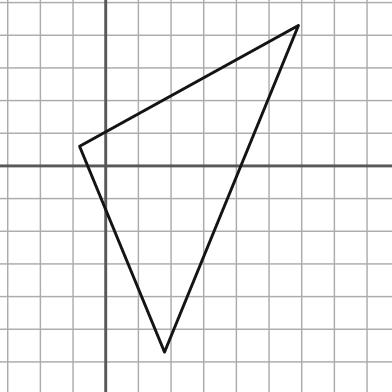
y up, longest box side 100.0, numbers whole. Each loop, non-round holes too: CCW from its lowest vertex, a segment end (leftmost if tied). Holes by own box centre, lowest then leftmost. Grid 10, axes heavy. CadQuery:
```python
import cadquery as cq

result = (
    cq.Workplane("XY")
    .moveTo(18.0, -57.0)
    .lineTo(59.0, 43.0)
    .lineTo(-8.0, 6.0)
    .close()
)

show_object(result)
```